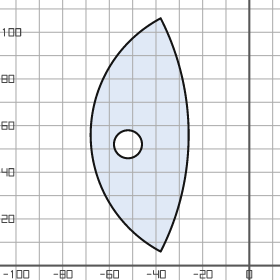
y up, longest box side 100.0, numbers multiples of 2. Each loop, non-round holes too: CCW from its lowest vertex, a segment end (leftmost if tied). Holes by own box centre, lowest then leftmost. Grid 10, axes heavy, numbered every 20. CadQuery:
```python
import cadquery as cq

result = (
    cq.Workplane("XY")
    .moveTo(-38.0, 6.0)
    .threePointArc((-26.0, 56.0), (-38.0, 106.0))
    .threePointArc((-68.0, 56.0), (-38.0, 6.0))
    .close()
    .moveTo(-52.0, 52.0)
    .circle(6.0)
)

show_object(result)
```